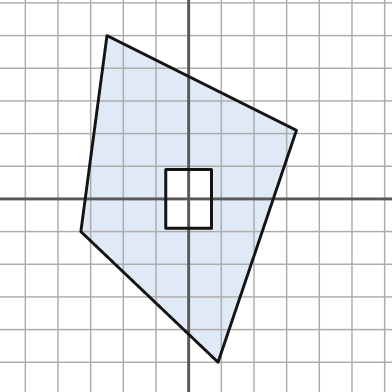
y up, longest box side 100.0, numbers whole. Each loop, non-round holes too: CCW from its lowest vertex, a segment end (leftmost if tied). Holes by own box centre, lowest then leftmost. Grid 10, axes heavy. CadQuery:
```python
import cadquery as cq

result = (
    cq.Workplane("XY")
    .moveTo(9.0, -50.0)
    .lineTo(33.0, 21.0)
    .lineTo(-25.0, 50.0)
    .lineTo(-33.0, -10.0)
    .close()
    .moveTo(-7.0, -9.0)
    .lineTo(7.0, -9.0)
    .lineTo(7.0, 9.0)
    .lineTo(-7.0, 9.0)
    .close()
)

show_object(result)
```